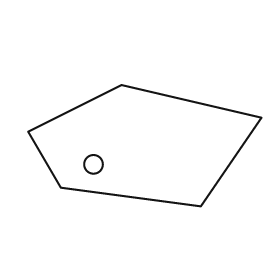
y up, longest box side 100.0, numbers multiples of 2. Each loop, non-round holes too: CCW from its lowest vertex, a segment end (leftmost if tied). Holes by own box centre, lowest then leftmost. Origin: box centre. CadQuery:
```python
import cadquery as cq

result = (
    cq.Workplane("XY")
    .moveTo(24.0, -26.0)
    .lineTo(50.0, 12.0)
    .lineTo(-10.0, 26.0)
    .lineTo(-50.0, 6.0)
    .lineTo(-36.0, -18.0)
    .close()
    .moveTo(-22.0, -8.0)
    .circle(4.0)
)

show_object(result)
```